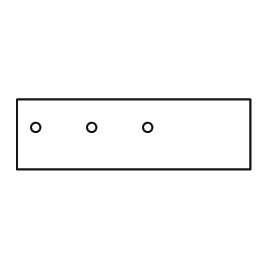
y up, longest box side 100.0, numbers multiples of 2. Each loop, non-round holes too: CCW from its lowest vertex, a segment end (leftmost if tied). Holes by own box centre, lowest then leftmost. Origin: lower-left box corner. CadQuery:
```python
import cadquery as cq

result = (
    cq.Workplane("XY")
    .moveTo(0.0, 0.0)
    .lineTo(100.0, 0.0)
    .lineTo(100.0, 30.0)
    .lineTo(0.0, 30.0)
    .close()
    .moveTo(8.0, 18.0)
    .circle(2.0)
    .moveTo(32.0, 18.0)
    .circle(2.0)
    .moveTo(56.0, 18.0)
    .circle(2.0)
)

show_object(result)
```